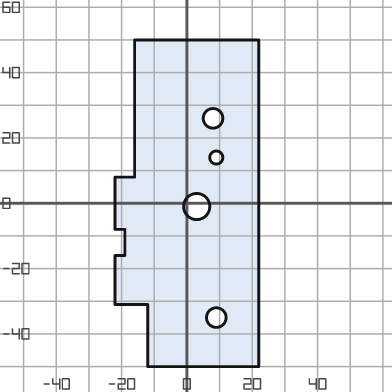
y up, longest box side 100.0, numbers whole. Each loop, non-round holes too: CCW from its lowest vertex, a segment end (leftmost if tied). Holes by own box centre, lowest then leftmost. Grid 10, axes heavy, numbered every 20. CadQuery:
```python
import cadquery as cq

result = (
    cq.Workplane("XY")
    .moveTo(-12.0, -50.0)
    .lineTo(22.0, -50.0)
    .lineTo(22.0, 50.0)
    .lineTo(-16.0, 50.0)
    .lineTo(-16.0, 8.0)
    .lineTo(-22.0, 8.0)
    .lineTo(-22.0, -8.0)
    .lineTo(-19.0, -8.0)
    .lineTo(-19.0, -16.0)
    .lineTo(-22.0, -16.0)
    .lineTo(-22.0, -31.0)
    .lineTo(-12.0, -31.0)
    .close()
    .moveTo(9.0, -35.0)
    .circle(3.0)
    .moveTo(3.0, -1.0)
    .circle(4.0)
    .moveTo(9.0, 14.0)
    .circle(2.0)
    .moveTo(8.0, 26.0)
    .circle(3.0)
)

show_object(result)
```